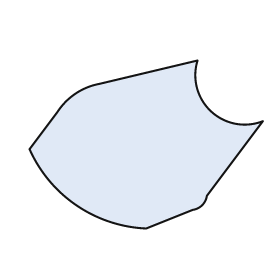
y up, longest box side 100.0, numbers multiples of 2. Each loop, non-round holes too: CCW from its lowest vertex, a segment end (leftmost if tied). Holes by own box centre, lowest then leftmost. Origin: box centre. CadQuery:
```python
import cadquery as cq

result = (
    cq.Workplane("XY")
    .moveTo(0.0, -36.0)
    .lineTo(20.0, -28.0)
    .threePointArc((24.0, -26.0), (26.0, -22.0))
    .lineTo(50.0, 10.0)
    .threePointArc((28.0, 14.0), (22.0, 36.0))
    .lineTo(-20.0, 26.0)
    .threePointArc((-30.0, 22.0), (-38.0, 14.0))
    .lineTo(-50.0, -2.0)
    .threePointArc((-30.0, -26.0), (0.0, -36.0))
    .close()
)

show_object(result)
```